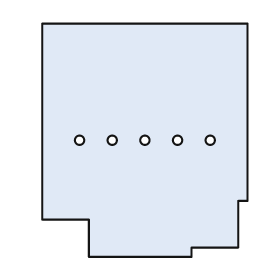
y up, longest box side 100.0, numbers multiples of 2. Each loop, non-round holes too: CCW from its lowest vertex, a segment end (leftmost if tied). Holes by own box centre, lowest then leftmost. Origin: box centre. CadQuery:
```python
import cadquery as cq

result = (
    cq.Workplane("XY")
    .moveTo(-24.0, -50.0)
    .lineTo(20.0, -50.0)
    .lineTo(20.0, -46.0)
    .lineTo(40.0, -46.0)
    .lineTo(40.0, -26.0)
    .lineTo(44.0, -26.0)
    .lineTo(44.0, 50.0)
    .lineTo(-44.0, 50.0)
    .lineTo(-44.0, -34.0)
    .lineTo(-24.0, -34.0)
    .close()
    .moveTo(-28.0, 0.0)
    .circle(2.0)
    .moveTo(-14.0, 0.0)
    .circle(2.0)
    .moveTo(0.0, 0.0)
    .circle(2.0)
    .moveTo(14.0, 0.0)
    .circle(2.0)
    .moveTo(28.0, 0.0)
    .circle(2.0)
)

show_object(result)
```